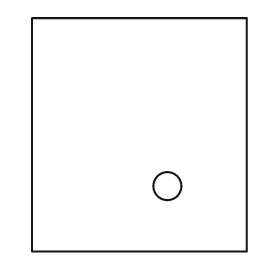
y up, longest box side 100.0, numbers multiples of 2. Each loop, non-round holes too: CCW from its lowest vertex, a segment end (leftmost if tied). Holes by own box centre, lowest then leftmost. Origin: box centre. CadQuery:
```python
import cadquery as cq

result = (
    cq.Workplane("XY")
    .moveTo(-46.0, -50.0)
    .lineTo(46.0, -50.0)
    .lineTo(46.0, 50.0)
    .lineTo(-46.0, 50.0)
    .close()
    .moveTo(12.0, -22.0)
    .circle(6.0)
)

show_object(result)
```